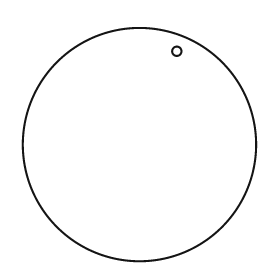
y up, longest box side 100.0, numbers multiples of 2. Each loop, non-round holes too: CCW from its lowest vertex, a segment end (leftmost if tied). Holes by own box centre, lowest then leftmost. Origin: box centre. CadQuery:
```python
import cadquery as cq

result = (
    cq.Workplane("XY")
    .moveTo(0.0, 0.0)
    .circle(50.0)
    .moveTo(16.0, 40.0)
    .circle(2.0)
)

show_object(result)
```